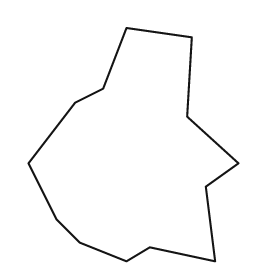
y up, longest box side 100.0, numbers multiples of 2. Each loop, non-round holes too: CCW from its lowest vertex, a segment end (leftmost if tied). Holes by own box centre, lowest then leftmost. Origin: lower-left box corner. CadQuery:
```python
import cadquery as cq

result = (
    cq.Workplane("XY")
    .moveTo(42.0, 0.0)
    .lineTo(52.0, 6.0)
    .lineTo(80.0, 0.0)
    .lineTo(76.0, 32.0)
    .lineTo(90.0, 42.0)
    .lineTo(68.0, 62.0)
    .lineTo(70.0, 96.0)
    .lineTo(42.0, 100.0)
    .lineTo(32.0, 74.0)
    .lineTo(20.0, 68.0)
    .lineTo(0.0, 42.0)
    .lineTo(12.0, 18.0)
    .lineTo(22.0, 8.0)
    .close()
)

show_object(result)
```